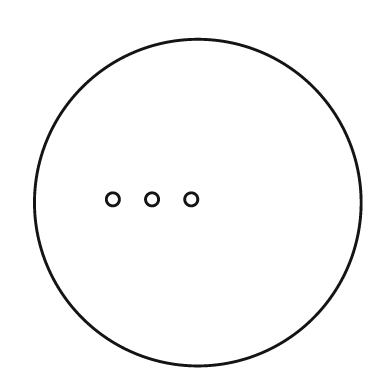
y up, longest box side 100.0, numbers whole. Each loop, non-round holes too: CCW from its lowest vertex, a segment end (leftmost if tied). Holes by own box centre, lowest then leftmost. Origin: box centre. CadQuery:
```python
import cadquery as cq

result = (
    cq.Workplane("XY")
    .moveTo(0.0, 0.0)
    .circle(50.0)
    .moveTo(-26.0, 1.0)
    .circle(2.0)
    .moveTo(-14.0, 1.0)
    .circle(2.0)
    .moveTo(-2.0, 1.0)
    .circle(2.0)
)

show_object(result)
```